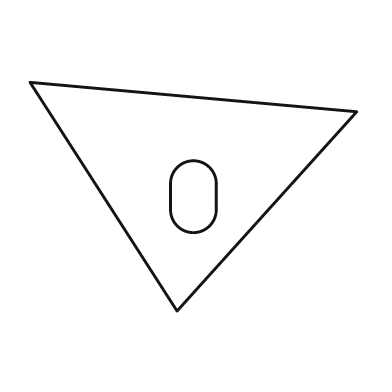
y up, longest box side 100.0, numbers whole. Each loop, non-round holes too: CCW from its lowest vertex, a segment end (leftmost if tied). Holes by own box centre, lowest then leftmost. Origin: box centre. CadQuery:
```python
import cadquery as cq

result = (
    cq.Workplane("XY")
    .moveTo(-5.0, -35.0)
    .lineTo(50.0, 26.0)
    .lineTo(-50.0, 35.0)
    .close()
    .moveTo(-7.0, -4.0)
    .threePointArc((0.0, -11.0), (7.0, -4.0))
    .lineTo(7.0, 4.0)
    .threePointArc((0.0, 11.0), (-7.0, 4.0))
    .close()
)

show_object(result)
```